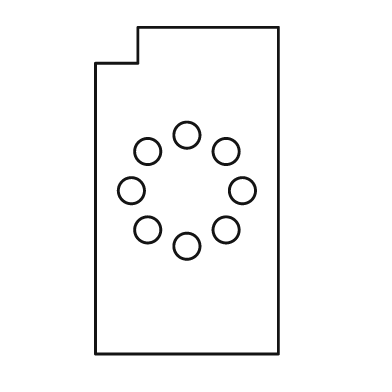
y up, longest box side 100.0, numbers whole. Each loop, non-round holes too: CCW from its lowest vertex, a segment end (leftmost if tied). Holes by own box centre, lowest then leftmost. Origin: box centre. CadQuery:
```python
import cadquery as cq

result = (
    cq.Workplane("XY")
    .moveTo(-28.0, -50.0)
    .lineTo(28.0, -50.0)
    .lineTo(28.0, 50.0)
    .lineTo(-15.0, 50.0)
    .lineTo(-15.0, 39.0)
    .lineTo(-28.0, 39.0)
    .close()
    .moveTo(0.0, -17.0)
    .circle(4.0)
    .moveTo(-12.0, -12.0)
    .circle(4.0)
    .moveTo(12.0, -12.0)
    .circle(4.0)
    .moveTo(-17.0, 0.0)
    .circle(4.0)
    .moveTo(17.0, 0.0)
    .circle(4.0)
    .moveTo(-12.0, 12.0)
    .circle(4.0)
    .moveTo(12.0, 12.0)
    .circle(4.0)
    .moveTo(0.0, 17.0)
    .circle(4.0)
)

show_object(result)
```